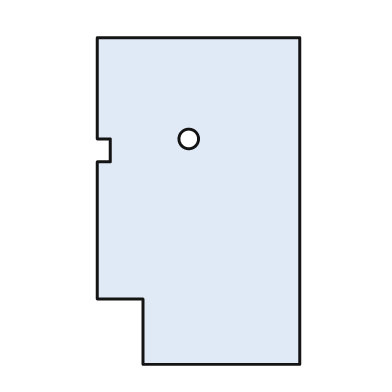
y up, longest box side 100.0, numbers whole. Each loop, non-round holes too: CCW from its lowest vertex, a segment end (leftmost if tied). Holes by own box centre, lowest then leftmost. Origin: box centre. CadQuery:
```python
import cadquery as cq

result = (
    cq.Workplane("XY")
    .moveTo(-17.0, -50.0)
    .lineTo(31.0, -50.0)
    .lineTo(31.0, 50.0)
    .lineTo(-31.0, 50.0)
    .lineTo(-31.0, 19.0)
    .lineTo(-27.0, 19.0)
    .lineTo(-27.0, 12.0)
    .lineTo(-31.0, 12.0)
    .lineTo(-31.0, -30.0)
    .lineTo(-17.0, -30.0)
    .close()
    .moveTo(-3.0, 19.0)
    .circle(3.0)
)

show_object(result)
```